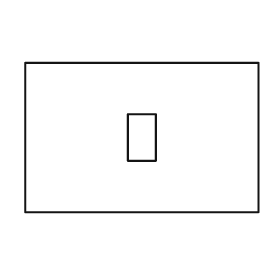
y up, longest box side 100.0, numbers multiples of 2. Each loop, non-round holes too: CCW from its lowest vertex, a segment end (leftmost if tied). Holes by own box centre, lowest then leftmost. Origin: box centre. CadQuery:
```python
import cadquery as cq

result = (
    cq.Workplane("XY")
    .moveTo(-50.0, -32.0)
    .lineTo(50.0, -32.0)
    .lineTo(50.0, 32.0)
    .lineTo(-50.0, 32.0)
    .close()
    .moveTo(-6.0, -10.0)
    .lineTo(6.0, -10.0)
    .lineTo(6.0, 10.0)
    .lineTo(-6.0, 10.0)
    .close()
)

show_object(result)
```